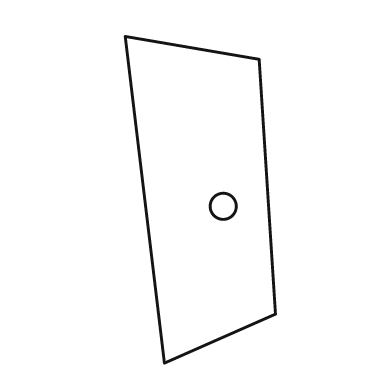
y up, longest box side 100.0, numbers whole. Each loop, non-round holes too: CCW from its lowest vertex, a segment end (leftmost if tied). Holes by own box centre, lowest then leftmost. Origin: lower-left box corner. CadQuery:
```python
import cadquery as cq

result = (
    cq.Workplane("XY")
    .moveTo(12.0, 0.0)
    .lineTo(46.0, 15.0)
    .lineTo(41.0, 93.0)
    .lineTo(0.0, 100.0)
    .close()
    .moveTo(30.0, 48.0)
    .circle(4.0)
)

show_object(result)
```